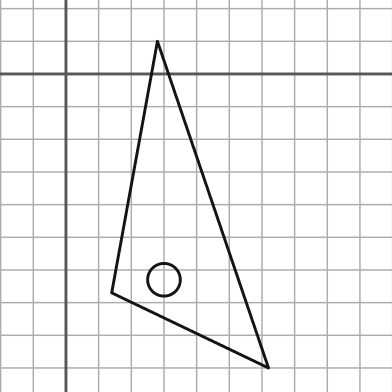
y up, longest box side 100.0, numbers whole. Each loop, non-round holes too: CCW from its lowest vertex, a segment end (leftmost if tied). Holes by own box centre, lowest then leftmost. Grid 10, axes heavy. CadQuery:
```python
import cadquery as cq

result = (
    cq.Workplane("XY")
    .moveTo(62.0, -90.0)
    .lineTo(28.0, 10.0)
    .lineTo(14.0, -67.0)
    .close()
    .moveTo(30.0, -63.0)
    .circle(5.0)
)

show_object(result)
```